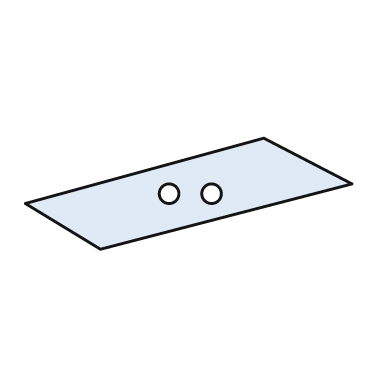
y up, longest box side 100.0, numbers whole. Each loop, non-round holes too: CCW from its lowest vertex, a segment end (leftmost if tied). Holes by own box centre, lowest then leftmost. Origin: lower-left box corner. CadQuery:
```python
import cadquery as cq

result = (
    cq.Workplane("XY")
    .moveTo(23.0, 0.0)
    .lineTo(100.0, 20.0)
    .lineTo(73.0, 34.0)
    .lineTo(0.0, 14.0)
    .close()
    .moveTo(44.0, 17.0)
    .circle(3.0)
    .moveTo(57.0, 17.0)
    .circle(3.0)
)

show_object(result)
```